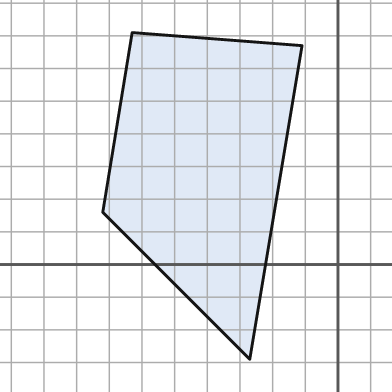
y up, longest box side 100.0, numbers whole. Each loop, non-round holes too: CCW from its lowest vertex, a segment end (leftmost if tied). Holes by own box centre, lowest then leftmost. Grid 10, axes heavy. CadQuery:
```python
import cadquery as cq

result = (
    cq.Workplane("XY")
    .moveTo(-27.0, -29.0)
    .lineTo(-11.0, 67.0)
    .lineTo(-63.0, 71.0)
    .lineTo(-72.0, 16.0)
    .close()
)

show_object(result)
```